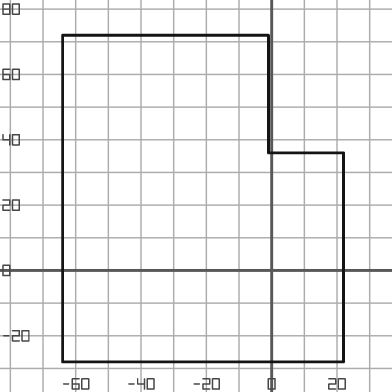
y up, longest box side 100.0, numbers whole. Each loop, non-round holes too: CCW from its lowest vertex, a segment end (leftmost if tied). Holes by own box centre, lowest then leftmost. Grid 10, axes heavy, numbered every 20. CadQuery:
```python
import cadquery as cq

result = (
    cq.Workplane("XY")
    .moveTo(-64.0, -28.0)
    .lineTo(22.0, -28.0)
    .lineTo(22.0, 36.0)
    .lineTo(-1.0, 36.0)
    .lineTo(-1.0, 72.0)
    .lineTo(-64.0, 72.0)
    .close()
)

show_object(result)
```